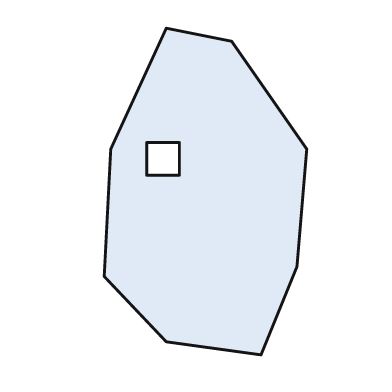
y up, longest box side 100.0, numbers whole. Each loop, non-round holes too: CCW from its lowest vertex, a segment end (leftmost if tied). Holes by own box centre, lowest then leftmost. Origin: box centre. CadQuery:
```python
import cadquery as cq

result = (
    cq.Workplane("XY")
    .moveTo(17.0, -50.0)
    .lineTo(28.0, -23.0)
    .lineTo(31.0, 13.0)
    .lineTo(8.0, 46.0)
    .lineTo(-12.0, 50.0)
    .lineTo(-29.0, 13.0)
    .lineTo(-31.0, -26.0)
    .lineTo(-12.0, -46.0)
    .close()
    .moveTo(-18.0, 5.0)
    .lineTo(-8.0, 5.0)
    .lineTo(-8.0, 15.0)
    .lineTo(-18.0, 15.0)
    .close()
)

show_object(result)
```